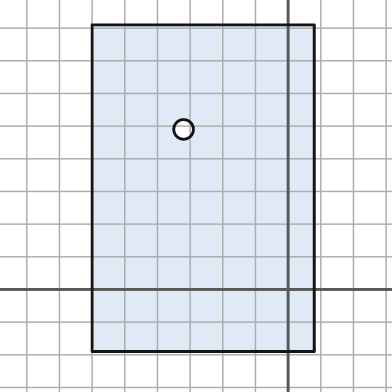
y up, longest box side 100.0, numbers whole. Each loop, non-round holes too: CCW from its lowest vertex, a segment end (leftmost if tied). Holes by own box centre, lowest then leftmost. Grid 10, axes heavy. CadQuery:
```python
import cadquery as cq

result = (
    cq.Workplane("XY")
    .moveTo(-60.0, -19.0)
    .lineTo(8.0, -19.0)
    .lineTo(8.0, 81.0)
    .lineTo(-60.0, 81.0)
    .close()
    .moveTo(-32.0, 49.0)
    .circle(3.0)
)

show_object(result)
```